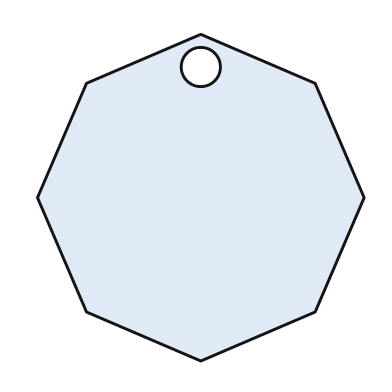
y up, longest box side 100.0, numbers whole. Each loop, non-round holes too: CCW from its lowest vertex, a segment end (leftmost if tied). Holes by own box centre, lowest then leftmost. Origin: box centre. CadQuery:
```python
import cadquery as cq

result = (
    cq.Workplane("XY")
    .moveTo(0.0, -50.0)
    .lineTo(35.0, -35.0)
    .lineTo(50.0, 0.0)
    .lineTo(35.0, 35.0)
    .lineTo(0.0, 50.0)
    .lineTo(-35.0, 35.0)
    .lineTo(-50.0, 0.0)
    .lineTo(-35.0, -35.0)
    .close()
    .moveTo(0.0, 40.0)
    .circle(6.0)
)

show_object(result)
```